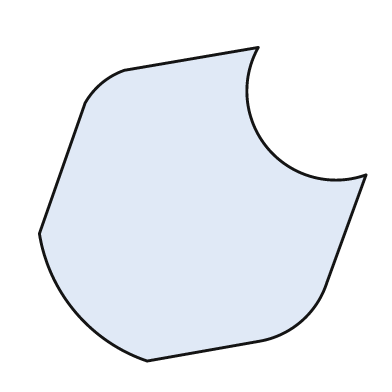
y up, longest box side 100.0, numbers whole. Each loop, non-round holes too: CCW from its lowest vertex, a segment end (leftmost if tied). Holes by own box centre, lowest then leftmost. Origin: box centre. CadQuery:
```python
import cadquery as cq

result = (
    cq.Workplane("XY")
    .moveTo(-17.0, -48.0)
    .lineTo(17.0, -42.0)
    .threePointArc((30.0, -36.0), (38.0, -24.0))
    .lineTo(50.0, 9.0)
    .threePointArc((20.0, 17.0), (17.0, 48.0))
    .lineTo(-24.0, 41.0)
    .threePointArc((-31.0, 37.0), (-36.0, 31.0))
    .lineTo(-50.0, -9.0)
    .threePointArc((-39.0, -33.0), (-17.0, -48.0))
    .close()
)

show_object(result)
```